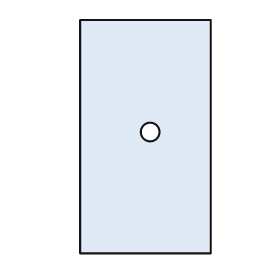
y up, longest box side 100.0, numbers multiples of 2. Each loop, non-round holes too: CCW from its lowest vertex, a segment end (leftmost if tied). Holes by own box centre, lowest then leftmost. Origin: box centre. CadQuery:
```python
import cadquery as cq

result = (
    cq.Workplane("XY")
    .moveTo(-28.0, -50.0)
    .lineTo(28.0, -50.0)
    .lineTo(28.0, 50.0)
    .lineTo(-28.0, 50.0)
    .close()
    .moveTo(2.0, 2.0)
    .circle(4.0)
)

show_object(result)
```